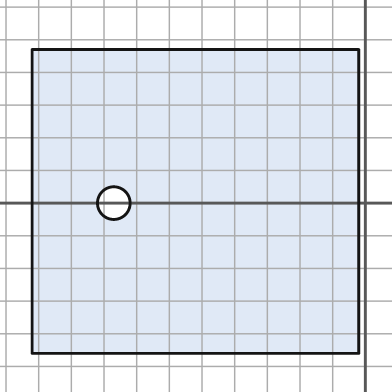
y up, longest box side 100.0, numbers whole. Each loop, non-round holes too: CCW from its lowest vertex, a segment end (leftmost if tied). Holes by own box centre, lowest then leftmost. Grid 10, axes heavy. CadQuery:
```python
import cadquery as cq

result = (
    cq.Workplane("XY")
    .moveTo(-102.0, -46.0)
    .lineTo(-2.0, -46.0)
    .lineTo(-2.0, 47.0)
    .lineTo(-102.0, 47.0)
    .close()
    .moveTo(-77.0, 0.0)
    .circle(5.0)
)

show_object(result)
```